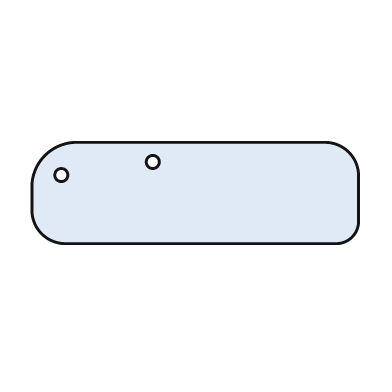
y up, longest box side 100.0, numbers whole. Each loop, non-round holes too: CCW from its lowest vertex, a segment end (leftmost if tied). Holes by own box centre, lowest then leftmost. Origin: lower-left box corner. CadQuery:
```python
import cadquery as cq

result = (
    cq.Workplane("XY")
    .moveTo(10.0, 0.0)
    .lineTo(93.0, 0.0)
    .threePointArc((98.0, 2.0), (100.0, 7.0))
    .lineTo(100.0, 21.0)
    .threePointArc((97.0, 28.0), (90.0, 31.0))
    .lineTo(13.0, 31.0)
    .threePointArc((4.0, 27.0), (0.0, 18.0))
    .lineTo(0.0, 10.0)
    .threePointArc((3.0, 3.0), (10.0, 0.0))
    .close()
    .moveTo(9.0, 21.0)
    .circle(2.0)
    .moveTo(37.0, 25.0)
    .circle(2.0)
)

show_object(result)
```